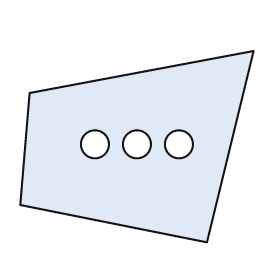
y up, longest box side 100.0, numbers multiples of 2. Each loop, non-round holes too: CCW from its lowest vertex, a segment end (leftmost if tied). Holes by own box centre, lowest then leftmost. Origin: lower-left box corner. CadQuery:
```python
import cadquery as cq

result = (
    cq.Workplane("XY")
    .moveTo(80.0, 0.0)
    .lineTo(100.0, 82.0)
    .lineTo(4.0, 64.0)
    .lineTo(0.0, 16.0)
    .close()
    .moveTo(32.0, 42.0)
    .circle(6.0)
    .moveTo(50.0, 42.0)
    .circle(6.0)
    .moveTo(68.0, 42.0)
    .circle(6.0)
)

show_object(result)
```